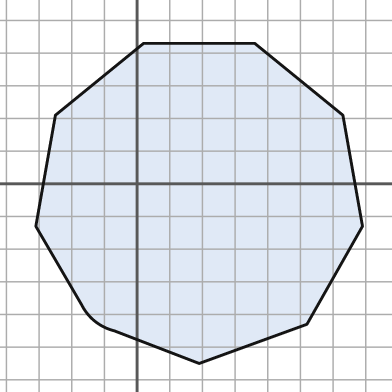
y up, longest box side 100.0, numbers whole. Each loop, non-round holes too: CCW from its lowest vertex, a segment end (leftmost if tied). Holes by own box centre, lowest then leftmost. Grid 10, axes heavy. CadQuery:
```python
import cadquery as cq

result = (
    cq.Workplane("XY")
    .moveTo(19.0, -55.0)
    .lineTo(52.0, -43.0)
    .lineTo(69.0, -13.0)
    .lineTo(63.0, 21.0)
    .lineTo(36.0, 43.0)
    .lineTo(2.0, 43.0)
    .lineTo(-25.0, 21.0)
    .lineTo(-31.0, -13.0)
    .lineTo(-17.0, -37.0)
    .threePointArc((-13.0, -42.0), (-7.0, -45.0))
    .close()
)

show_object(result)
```